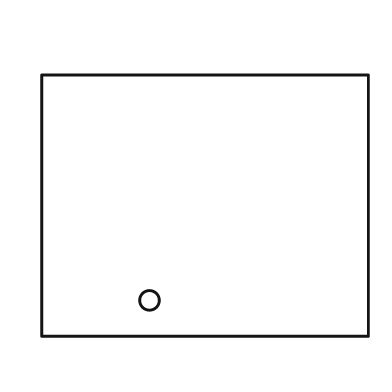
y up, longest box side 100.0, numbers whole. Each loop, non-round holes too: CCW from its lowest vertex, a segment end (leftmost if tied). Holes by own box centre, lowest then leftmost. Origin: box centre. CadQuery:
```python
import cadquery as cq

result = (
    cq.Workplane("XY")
    .moveTo(-50.0, -40.0)
    .lineTo(50.0, -40.0)
    .lineTo(50.0, 40.0)
    .lineTo(-50.0, 40.0)
    .close()
    .moveTo(-17.0, -29.0)
    .circle(3.0)
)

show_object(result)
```